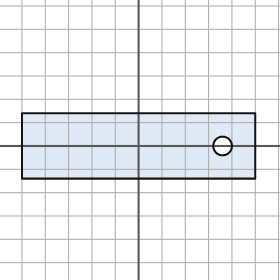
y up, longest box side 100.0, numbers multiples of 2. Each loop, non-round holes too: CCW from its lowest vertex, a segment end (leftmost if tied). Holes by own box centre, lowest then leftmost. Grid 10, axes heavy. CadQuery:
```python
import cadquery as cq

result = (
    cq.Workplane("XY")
    .moveTo(-50.0, -14.0)
    .lineTo(50.0, -14.0)
    .lineTo(50.0, 14.0)
    .lineTo(-50.0, 14.0)
    .close()
    .moveTo(36.0, 0.0)
    .circle(4.0)
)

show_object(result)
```